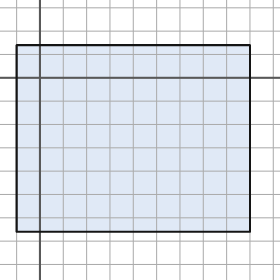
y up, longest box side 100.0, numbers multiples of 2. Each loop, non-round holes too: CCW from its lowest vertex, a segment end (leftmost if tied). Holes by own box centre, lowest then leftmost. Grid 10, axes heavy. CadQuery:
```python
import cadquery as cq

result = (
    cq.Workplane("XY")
    .moveTo(-10.0, -66.0)
    .lineTo(90.0, -66.0)
    .lineTo(90.0, 14.0)
    .lineTo(-10.0, 14.0)
    .close()
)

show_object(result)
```